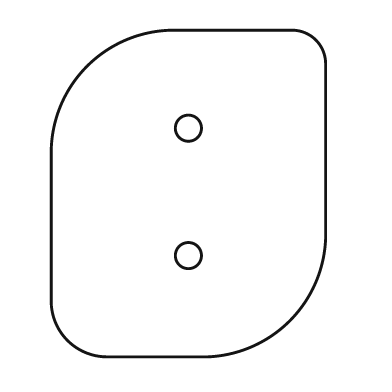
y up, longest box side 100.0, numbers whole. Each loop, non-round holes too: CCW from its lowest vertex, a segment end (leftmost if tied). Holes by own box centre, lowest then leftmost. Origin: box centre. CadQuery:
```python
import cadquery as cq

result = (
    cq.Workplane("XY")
    .moveTo(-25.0, -50.0)
    .lineTo(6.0, -50.0)
    .threePointArc((31.0, -39.0), (42.0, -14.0))
    .lineTo(42.0, 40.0)
    .threePointArc((39.0, 47.0), (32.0, 50.0))
    .lineTo(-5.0, 50.0)
    .threePointArc((-31.0, 39.0), (-42.0, 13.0))
    .lineTo(-42.0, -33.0)
    .threePointArc((-37.0, -45.0), (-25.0, -50.0))
    .close()
    .moveTo(0.0, -19.0)
    .circle(4.0)
    .moveTo(0.0, 20.0)
    .circle(4.0)
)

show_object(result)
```